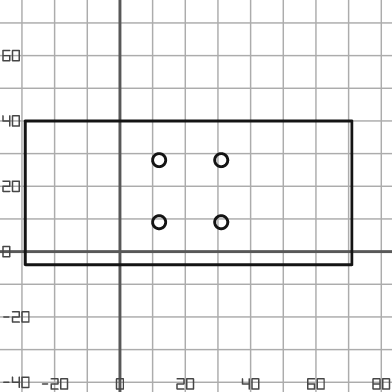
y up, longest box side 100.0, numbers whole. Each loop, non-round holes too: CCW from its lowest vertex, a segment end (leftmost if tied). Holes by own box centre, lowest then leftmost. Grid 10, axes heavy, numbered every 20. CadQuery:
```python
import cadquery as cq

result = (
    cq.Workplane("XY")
    .moveTo(-29.0, -4.0)
    .lineTo(71.0, -4.0)
    .lineTo(71.0, 40.0)
    .lineTo(-29.0, 40.0)
    .close()
    .moveTo(12.0, 9.0)
    .circle(2.0)
    .moveTo(31.0, 9.0)
    .circle(2.0)
    .moveTo(12.0, 28.0)
    .circle(2.0)
    .moveTo(31.0, 28.0)
    .circle(2.0)
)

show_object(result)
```